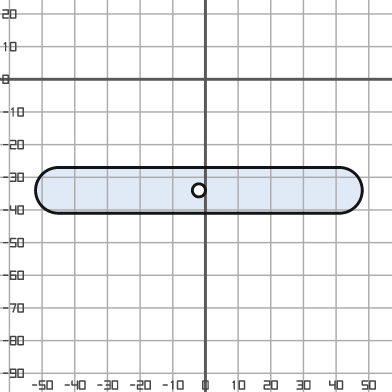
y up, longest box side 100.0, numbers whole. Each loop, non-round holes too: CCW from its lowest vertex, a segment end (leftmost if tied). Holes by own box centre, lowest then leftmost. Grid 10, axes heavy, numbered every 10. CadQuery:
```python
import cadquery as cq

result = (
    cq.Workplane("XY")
    .moveTo(-45.0, -41.0)
    .lineTo(41.0, -41.0)
    .threePointArc((48.0, -34.0), (41.0, -27.0))
    .lineTo(-45.0, -27.0)
    .threePointArc((-52.0, -34.0), (-45.0, -41.0))
    .close()
    .moveTo(-2.0, -34.0)
    .circle(2.0)
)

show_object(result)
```